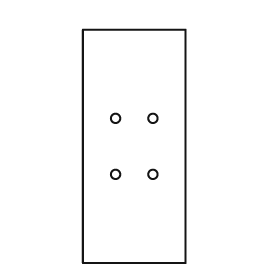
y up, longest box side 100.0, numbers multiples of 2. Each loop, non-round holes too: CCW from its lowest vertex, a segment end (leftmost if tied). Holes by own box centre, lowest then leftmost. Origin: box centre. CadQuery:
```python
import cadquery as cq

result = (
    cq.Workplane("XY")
    .moveTo(-22.0, -50.0)
    .lineTo(22.0, -50.0)
    .lineTo(22.0, 50.0)
    .lineTo(-22.0, 50.0)
    .close()
    .moveTo(-8.0, -12.0)
    .circle(2.0)
    .moveTo(8.0, -12.0)
    .circle(2.0)
    .moveTo(-8.0, 12.0)
    .circle(2.0)
    .moveTo(8.0, 12.0)
    .circle(2.0)
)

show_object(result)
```